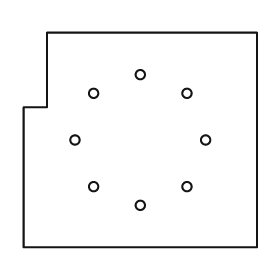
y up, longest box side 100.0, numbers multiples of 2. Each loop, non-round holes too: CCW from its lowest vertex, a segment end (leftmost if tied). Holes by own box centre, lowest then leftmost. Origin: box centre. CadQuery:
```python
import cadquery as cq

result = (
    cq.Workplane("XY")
    .moveTo(-50.0, -46.0)
    .lineTo(50.0, -46.0)
    .lineTo(50.0, 46.0)
    .lineTo(-40.0, 46.0)
    .lineTo(-40.0, 14.0)
    .lineTo(-50.0, 14.0)
    .close()
    .moveTo(0.0, -28.0)
    .circle(2.0)
    .moveTo(-20.0, -20.0)
    .circle(2.0)
    .moveTo(20.0, -20.0)
    .circle(2.0)
    .moveTo(-28.0, 0.0)
    .circle(2.0)
    .moveTo(28.0, 0.0)
    .circle(2.0)
    .moveTo(-20.0, 20.0)
    .circle(2.0)
    .moveTo(20.0, 20.0)
    .circle(2.0)
    .moveTo(0.0, 28.0)
    .circle(2.0)
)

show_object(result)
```